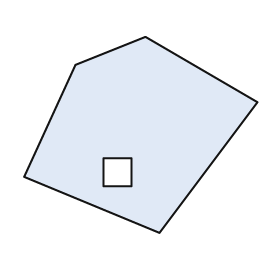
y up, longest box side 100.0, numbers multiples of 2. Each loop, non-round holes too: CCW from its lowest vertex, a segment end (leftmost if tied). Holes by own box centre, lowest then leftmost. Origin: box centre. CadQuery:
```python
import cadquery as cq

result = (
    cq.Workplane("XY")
    .moveTo(8.0, -42.0)
    .lineTo(50.0, 14.0)
    .lineTo(2.0, 42.0)
    .lineTo(-28.0, 30.0)
    .lineTo(-50.0, -18.0)
    .close()
    .moveTo(-16.0, -22.0)
    .lineTo(-4.0, -22.0)
    .lineTo(-4.0, -10.0)
    .lineTo(-16.0, -10.0)
    .close()
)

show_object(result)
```